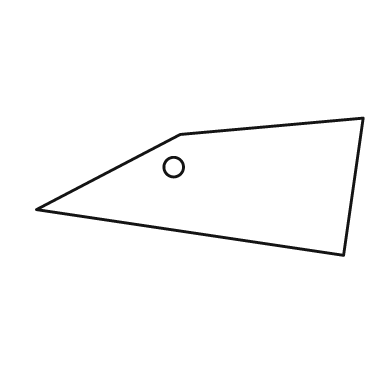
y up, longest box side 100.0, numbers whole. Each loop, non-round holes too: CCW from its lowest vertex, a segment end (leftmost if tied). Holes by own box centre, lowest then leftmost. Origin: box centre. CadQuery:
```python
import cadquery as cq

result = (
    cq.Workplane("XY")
    .moveTo(44.0, -21.0)
    .lineTo(50.0, 21.0)
    .lineTo(-6.0, 16.0)
    .lineTo(-50.0, -7.0)
    .close()
    .moveTo(-8.0, 6.0)
    .circle(3.0)
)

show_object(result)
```